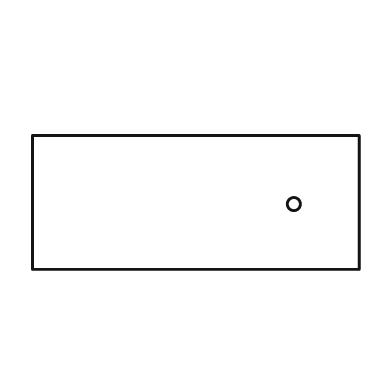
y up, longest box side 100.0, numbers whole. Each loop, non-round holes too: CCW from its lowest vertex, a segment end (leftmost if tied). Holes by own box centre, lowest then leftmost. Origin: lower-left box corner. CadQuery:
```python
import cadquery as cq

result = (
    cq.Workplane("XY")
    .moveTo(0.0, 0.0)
    .lineTo(100.0, 0.0)
    .lineTo(100.0, 41.0)
    .lineTo(0.0, 41.0)
    .close()
    .moveTo(80.0, 20.0)
    .circle(2.0)
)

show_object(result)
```